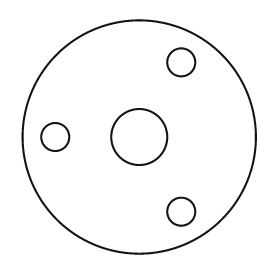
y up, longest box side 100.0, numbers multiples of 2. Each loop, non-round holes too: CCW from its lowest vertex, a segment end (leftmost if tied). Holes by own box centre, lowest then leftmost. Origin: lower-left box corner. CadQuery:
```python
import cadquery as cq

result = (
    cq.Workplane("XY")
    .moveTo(50.0, 50.0)
    .circle(50.0)
    .moveTo(68.0, 18.0)
    .circle(6.0)
    .moveTo(14.0, 50.0)
    .circle(6.0)
    .moveTo(50.0, 50.0)
    .circle(12.0)
    .moveTo(68.0, 82.0)
    .circle(6.0)
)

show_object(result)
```